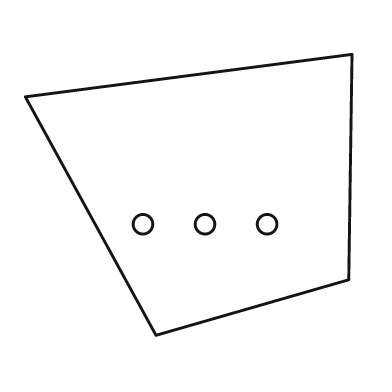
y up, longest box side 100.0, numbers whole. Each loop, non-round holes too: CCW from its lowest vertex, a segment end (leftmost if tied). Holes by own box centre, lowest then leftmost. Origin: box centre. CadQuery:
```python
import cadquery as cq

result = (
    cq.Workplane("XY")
    .moveTo(-10.0, -43.0)
    .lineTo(49.0, -26.0)
    .lineTo(50.0, 43.0)
    .lineTo(-50.0, 30.0)
    .close()
    .moveTo(-14.0, -9.0)
    .circle(3.0)
    .moveTo(5.0, -9.0)
    .circle(3.0)
    .moveTo(24.0, -9.0)
    .circle(3.0)
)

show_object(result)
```